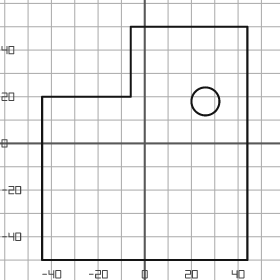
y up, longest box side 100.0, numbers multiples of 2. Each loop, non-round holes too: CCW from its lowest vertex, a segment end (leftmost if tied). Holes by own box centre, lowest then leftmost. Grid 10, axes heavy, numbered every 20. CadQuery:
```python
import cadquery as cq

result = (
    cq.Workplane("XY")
    .moveTo(-44.0, -50.0)
    .lineTo(44.0, -50.0)
    .lineTo(44.0, 50.0)
    .lineTo(-6.0, 50.0)
    .lineTo(-6.0, 20.0)
    .lineTo(-44.0, 20.0)
    .close()
    .moveTo(26.0, 18.0)
    .circle(6.0)
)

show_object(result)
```